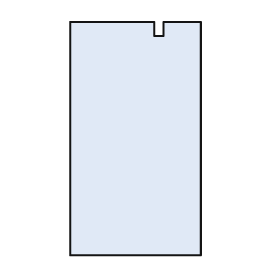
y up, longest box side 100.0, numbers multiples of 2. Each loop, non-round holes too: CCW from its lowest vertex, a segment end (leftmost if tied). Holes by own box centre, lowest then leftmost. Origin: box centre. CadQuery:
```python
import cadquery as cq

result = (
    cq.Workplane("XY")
    .moveTo(-28.0, -50.0)
    .lineTo(28.0, -50.0)
    .lineTo(28.0, 50.0)
    .lineTo(12.0, 50.0)
    .lineTo(12.0, 44.0)
    .lineTo(8.0, 44.0)
    .lineTo(8.0, 50.0)
    .lineTo(-28.0, 50.0)
    .close()
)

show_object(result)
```